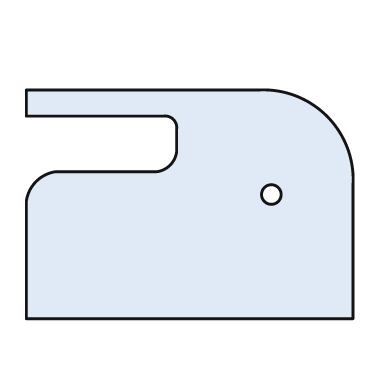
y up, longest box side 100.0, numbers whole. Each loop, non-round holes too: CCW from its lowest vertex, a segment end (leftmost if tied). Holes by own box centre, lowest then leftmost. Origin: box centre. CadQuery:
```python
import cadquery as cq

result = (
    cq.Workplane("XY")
    .moveTo(-50.0, -35.0)
    .lineTo(50.0, -35.0)
    .lineTo(50.0, 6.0)
    .threePointArc((42.0, 27.0), (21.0, 35.0))
    .lineTo(-50.0, 35.0)
    .lineTo(-50.0, 27.0)
    .lineTo(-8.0, 27.0)
    .threePointArc((-5.0, 26.0), (-4.0, 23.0))
    .lineTo(-4.0, 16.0)
    .threePointArc((-6.0, 12.0), (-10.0, 10.0))
    .lineTo(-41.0, 10.0)
    .threePointArc((-47.0, 7.0), (-50.0, 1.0))
    .close()
    .moveTo(25.0, 3.0)
    .circle(3.0)
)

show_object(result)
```